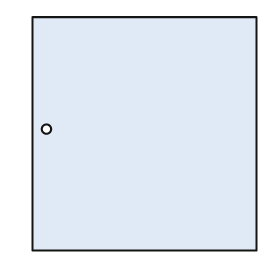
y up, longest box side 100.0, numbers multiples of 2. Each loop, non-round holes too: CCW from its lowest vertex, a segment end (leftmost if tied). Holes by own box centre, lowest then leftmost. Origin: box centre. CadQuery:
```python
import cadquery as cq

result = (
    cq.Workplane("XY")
    .moveTo(-48.0, -50.0)
    .lineTo(48.0, -50.0)
    .lineTo(48.0, 50.0)
    .lineTo(-48.0, 50.0)
    .close()
    .moveTo(-42.0, 2.0)
    .circle(2.0)
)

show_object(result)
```